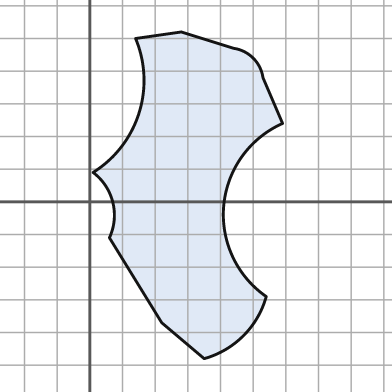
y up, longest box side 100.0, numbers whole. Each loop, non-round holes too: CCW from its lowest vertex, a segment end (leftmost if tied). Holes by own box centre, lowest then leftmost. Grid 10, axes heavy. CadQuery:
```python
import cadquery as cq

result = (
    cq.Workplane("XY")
    .moveTo(35.0, -48.0)
    .threePointArc((47.0, -41.0), (54.0, -29.0))
    .threePointArc((41.0, -1.0), (59.0, 24.0))
    .lineTo(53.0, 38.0)
    .threePointArc((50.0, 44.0), (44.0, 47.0))
    .lineTo(28.0, 52.0)
    .lineTo(14.0, 50.0)
    .threePointArc((15.0, 27.0), (1.0, 9.0))
    .threePointArc((7.0, 0.0), (6.0, -11.0))
    .lineTo(22.0, -37.0)
    .close()
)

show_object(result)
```